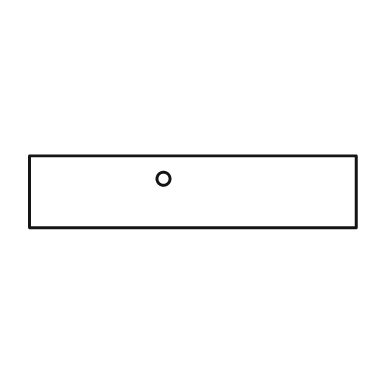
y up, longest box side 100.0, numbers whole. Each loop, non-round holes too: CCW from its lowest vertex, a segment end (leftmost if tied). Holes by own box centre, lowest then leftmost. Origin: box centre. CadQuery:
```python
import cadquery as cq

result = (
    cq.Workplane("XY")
    .moveTo(-50.0, -11.0)
    .lineTo(50.0, -11.0)
    .lineTo(50.0, 11.0)
    .lineTo(-50.0, 11.0)
    .close()
    .moveTo(-9.0, 4.0)
    .circle(2.0)
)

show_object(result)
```